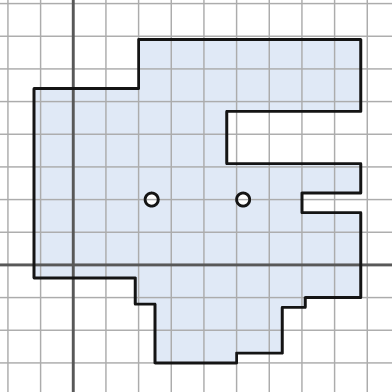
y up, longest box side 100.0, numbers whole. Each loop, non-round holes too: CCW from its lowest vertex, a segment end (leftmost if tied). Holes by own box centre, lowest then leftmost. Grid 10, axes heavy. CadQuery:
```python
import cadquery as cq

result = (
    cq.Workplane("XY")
    .moveTo(25.0, -30.0)
    .lineTo(50.0, -30.0)
    .lineTo(50.0, -27.0)
    .lineTo(64.0, -27.0)
    .lineTo(64.0, -13.0)
    .lineTo(71.0, -13.0)
    .lineTo(71.0, -10.0)
    .lineTo(88.0, -10.0)
    .lineTo(88.0, 16.0)
    .lineTo(70.0, 16.0)
    .lineTo(70.0, 22.0)
    .lineTo(88.0, 22.0)
    .lineTo(88.0, 31.0)
    .lineTo(47.0, 31.0)
    .lineTo(47.0, 47.0)
    .lineTo(88.0, 47.0)
    .lineTo(88.0, 69.0)
    .lineTo(20.0, 69.0)
    .lineTo(20.0, 54.0)
    .lineTo(-12.0, 54.0)
    .lineTo(-12.0, -4.0)
    .lineTo(19.0, -4.0)
    .lineTo(19.0, -12.0)
    .lineTo(25.0, -12.0)
    .close()
    .moveTo(24.0, 20.0)
    .circle(2.0)
    .moveTo(52.0, 20.0)
    .circle(2.0)
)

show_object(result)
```